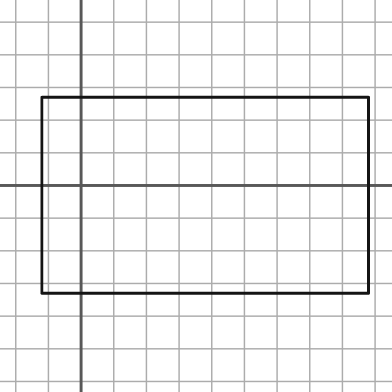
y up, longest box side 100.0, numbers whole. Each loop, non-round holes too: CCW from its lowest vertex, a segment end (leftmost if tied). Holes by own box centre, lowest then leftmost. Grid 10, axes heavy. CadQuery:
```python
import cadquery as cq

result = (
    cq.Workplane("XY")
    .moveTo(-12.0, -33.0)
    .lineTo(88.0, -33.0)
    .lineTo(88.0, 27.0)
    .lineTo(-12.0, 27.0)
    .close()
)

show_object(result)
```